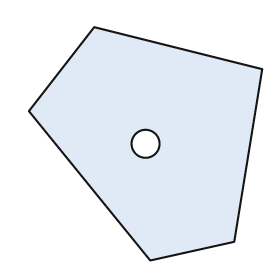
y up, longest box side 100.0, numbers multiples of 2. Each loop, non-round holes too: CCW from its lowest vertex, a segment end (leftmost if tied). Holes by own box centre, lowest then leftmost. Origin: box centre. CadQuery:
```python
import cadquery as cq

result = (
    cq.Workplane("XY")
    .moveTo(2.0, -50.0)
    .lineTo(38.0, -42.0)
    .lineTo(50.0, 32.0)
    .lineTo(-22.0, 50.0)
    .lineTo(-50.0, 14.0)
    .close()
    .moveTo(0.0, 0.0)
    .circle(6.0)
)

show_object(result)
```